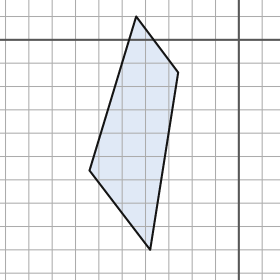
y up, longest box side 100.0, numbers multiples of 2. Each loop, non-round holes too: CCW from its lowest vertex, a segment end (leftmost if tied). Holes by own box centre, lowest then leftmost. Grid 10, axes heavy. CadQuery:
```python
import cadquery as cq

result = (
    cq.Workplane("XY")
    .moveTo(-38.0, -90.0)
    .lineTo(-26.0, -14.0)
    .lineTo(-44.0, 10.0)
    .lineTo(-64.0, -56.0)
    .close()
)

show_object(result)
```